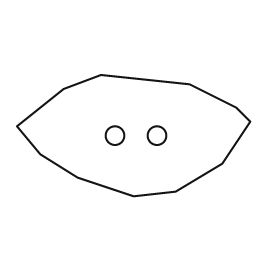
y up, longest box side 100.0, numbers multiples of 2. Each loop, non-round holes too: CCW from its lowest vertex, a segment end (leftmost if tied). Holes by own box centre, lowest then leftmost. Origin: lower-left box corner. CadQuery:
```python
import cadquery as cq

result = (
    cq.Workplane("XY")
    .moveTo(50.0, 0.0)
    .lineTo(68.0, 2.0)
    .lineTo(88.0, 14.0)
    .lineTo(100.0, 32.0)
    .lineTo(94.0, 38.0)
    .lineTo(74.0, 48.0)
    .lineTo(36.0, 52.0)
    .lineTo(20.0, 46.0)
    .lineTo(0.0, 30.0)
    .lineTo(10.0, 18.0)
    .lineTo(26.0, 8.0)
    .close()
    .moveTo(42.0, 26.0)
    .circle(4.0)
    .moveTo(60.0, 26.0)
    .circle(4.0)
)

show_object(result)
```